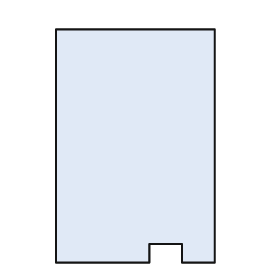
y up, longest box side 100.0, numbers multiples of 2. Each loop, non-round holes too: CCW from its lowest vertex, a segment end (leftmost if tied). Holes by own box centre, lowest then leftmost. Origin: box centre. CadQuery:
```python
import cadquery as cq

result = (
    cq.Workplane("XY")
    .moveTo(-34.0, -50.0)
    .lineTo(6.0, -50.0)
    .lineTo(6.0, -42.0)
    .lineTo(20.0, -42.0)
    .lineTo(20.0, -50.0)
    .lineTo(34.0, -50.0)
    .lineTo(34.0, 50.0)
    .lineTo(-34.0, 50.0)
    .close()
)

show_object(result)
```